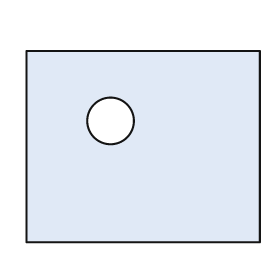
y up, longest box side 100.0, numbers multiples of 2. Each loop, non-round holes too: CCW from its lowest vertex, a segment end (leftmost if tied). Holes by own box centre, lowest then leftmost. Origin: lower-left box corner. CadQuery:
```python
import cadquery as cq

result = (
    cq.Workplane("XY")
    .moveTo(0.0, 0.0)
    .lineTo(100.0, 0.0)
    .lineTo(100.0, 82.0)
    .lineTo(0.0, 82.0)
    .close()
    .moveTo(36.0, 52.0)
    .circle(10.0)
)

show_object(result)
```